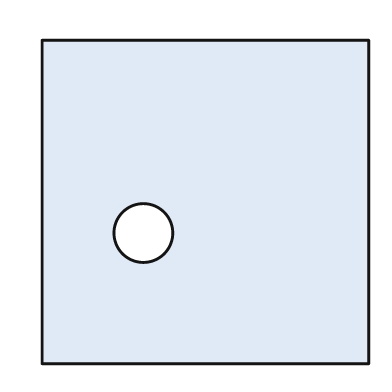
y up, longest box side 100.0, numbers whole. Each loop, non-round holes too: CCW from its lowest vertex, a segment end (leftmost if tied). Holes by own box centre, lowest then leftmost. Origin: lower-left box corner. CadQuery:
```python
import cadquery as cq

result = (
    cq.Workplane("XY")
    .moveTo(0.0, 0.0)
    .lineTo(100.0, 0.0)
    .lineTo(100.0, 99.0)
    .lineTo(0.0, 99.0)
    .close()
    .moveTo(31.0, 40.0)
    .circle(9.0)
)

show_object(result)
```